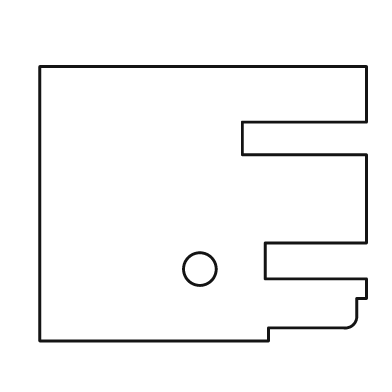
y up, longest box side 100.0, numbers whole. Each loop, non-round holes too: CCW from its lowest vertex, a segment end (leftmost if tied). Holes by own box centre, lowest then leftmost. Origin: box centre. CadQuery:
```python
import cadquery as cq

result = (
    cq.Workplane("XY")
    .moveTo(-50.0, -42.0)
    .lineTo(20.0, -42.0)
    .lineTo(20.0, -38.0)
    .lineTo(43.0, -38.0)
    .threePointArc((46.0, -37.0), (47.0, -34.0))
    .lineTo(47.0, -29.0)
    .lineTo(50.0, -29.0)
    .lineTo(50.0, -23.0)
    .lineTo(19.0, -23.0)
    .lineTo(19.0, -12.0)
    .lineTo(50.0, -12.0)
    .lineTo(50.0, 15.0)
    .lineTo(12.0, 15.0)
    .lineTo(12.0, 25.0)
    .lineTo(50.0, 25.0)
    .lineTo(50.0, 42.0)
    .lineTo(-50.0, 42.0)
    .close()
    .moveTo(-1.0, -20.0)
    .circle(5.0)
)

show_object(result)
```